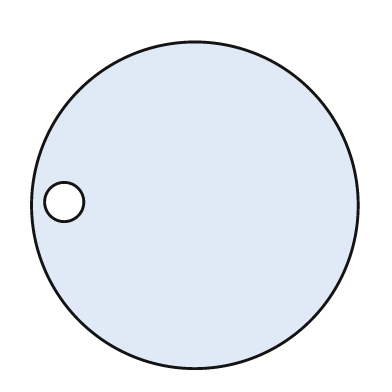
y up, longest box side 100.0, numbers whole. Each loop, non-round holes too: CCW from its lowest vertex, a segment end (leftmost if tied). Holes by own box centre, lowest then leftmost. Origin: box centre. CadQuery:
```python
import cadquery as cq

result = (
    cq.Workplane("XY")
    .moveTo(0.0, 0.0)
    .circle(50.0)
    .moveTo(-40.0, 1.0)
    .circle(6.0)
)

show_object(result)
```